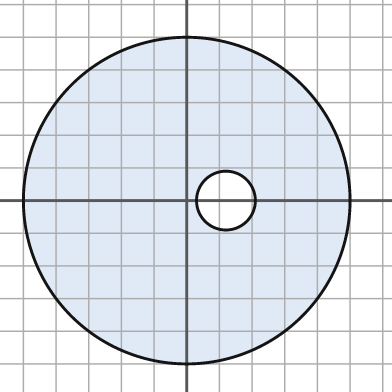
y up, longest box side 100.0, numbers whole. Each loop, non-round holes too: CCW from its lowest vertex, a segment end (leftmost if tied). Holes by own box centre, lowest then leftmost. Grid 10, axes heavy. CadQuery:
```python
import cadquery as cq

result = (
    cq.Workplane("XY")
    .moveTo(0.0, 0.0)
    .circle(50.0)
    .moveTo(12.0, 0.0)
    .circle(9.0)
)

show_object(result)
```